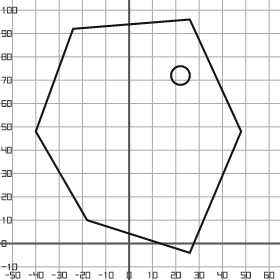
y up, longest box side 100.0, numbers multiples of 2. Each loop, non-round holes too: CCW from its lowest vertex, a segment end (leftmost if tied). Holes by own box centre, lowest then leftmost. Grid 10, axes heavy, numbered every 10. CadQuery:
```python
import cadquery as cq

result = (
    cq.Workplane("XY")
    .moveTo(26.0, -4.0)
    .lineTo(48.0, 48.0)
    .lineTo(26.0, 96.0)
    .lineTo(-24.0, 92.0)
    .lineTo(-40.0, 48.0)
    .lineTo(-18.0, 10.0)
    .close()
    .moveTo(22.0, 72.0)
    .circle(4.0)
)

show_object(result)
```